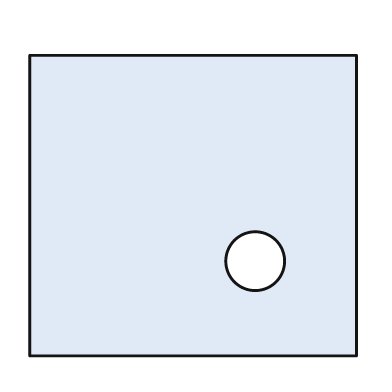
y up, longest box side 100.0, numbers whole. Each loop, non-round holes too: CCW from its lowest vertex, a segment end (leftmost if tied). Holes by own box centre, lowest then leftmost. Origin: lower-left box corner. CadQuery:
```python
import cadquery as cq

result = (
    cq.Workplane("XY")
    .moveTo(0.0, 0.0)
    .lineTo(100.0, 0.0)
    .lineTo(100.0, 92.0)
    .lineTo(0.0, 92.0)
    .close()
    .moveTo(69.0, 29.0)
    .circle(9.0)
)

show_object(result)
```